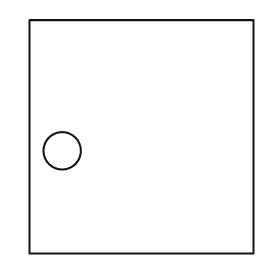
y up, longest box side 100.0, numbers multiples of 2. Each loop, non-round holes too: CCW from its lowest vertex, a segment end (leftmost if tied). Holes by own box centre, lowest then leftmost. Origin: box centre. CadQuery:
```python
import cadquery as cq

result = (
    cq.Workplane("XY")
    .moveTo(-48.0, -50.0)
    .lineTo(48.0, -50.0)
    .lineTo(48.0, 50.0)
    .lineTo(-48.0, 50.0)
    .close()
    .moveTo(-34.0, -6.0)
    .circle(8.0)
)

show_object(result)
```